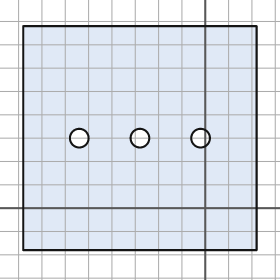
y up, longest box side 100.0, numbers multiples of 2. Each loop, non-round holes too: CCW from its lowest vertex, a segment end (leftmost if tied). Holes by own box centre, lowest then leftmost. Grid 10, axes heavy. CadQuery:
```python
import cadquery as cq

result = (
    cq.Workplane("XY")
    .moveTo(-78.0, -18.0)
    .lineTo(22.0, -18.0)
    .lineTo(22.0, 78.0)
    .lineTo(-78.0, 78.0)
    .close()
    .moveTo(-54.0, 30.0)
    .circle(4.0)
    .moveTo(-28.0, 30.0)
    .circle(4.0)
    .moveTo(-2.0, 30.0)
    .circle(4.0)
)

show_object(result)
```